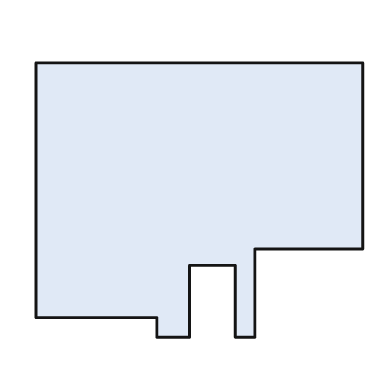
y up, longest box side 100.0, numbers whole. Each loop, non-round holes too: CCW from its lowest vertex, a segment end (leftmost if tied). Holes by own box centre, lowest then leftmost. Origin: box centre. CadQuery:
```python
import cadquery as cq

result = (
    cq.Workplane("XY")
    .moveTo(-13.0, -42.0)
    .lineTo(-3.0, -42.0)
    .lineTo(-3.0, -20.0)
    .lineTo(11.0, -20.0)
    .lineTo(11.0, -42.0)
    .lineTo(17.0, -42.0)
    .lineTo(17.0, -15.0)
    .lineTo(50.0, -15.0)
    .lineTo(50.0, 42.0)
    .lineTo(-50.0, 42.0)
    .lineTo(-50.0, -36.0)
    .lineTo(-13.0, -36.0)
    .close()
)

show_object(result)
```